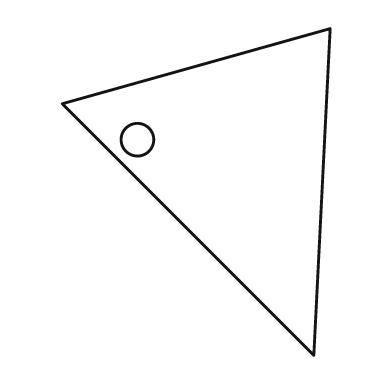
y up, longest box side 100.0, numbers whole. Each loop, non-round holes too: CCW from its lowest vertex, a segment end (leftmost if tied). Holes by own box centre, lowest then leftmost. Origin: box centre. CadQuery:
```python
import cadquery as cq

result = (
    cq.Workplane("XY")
    .moveTo(36.0, -50.0)
    .lineTo(41.0, 50.0)
    .lineTo(-41.0, 27.0)
    .close()
    .moveTo(-18.0, 16.0)
    .circle(5.0)
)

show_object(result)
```